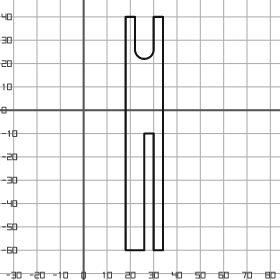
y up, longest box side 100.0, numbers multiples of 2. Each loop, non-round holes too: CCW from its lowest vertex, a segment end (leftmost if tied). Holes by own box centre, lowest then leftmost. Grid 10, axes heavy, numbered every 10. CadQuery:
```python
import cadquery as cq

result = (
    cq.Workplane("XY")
    .moveTo(18.0, -60.0)
    .lineTo(26.0, -60.0)
    .lineTo(26.0, -10.0)
    .lineTo(30.0, -10.0)
    .lineTo(30.0, -60.0)
    .lineTo(34.0, -60.0)
    .lineTo(34.0, 40.0)
    .lineTo(30.0, 40.0)
    .lineTo(30.0, 26.0)
    .threePointArc((26.0, 22.0), (22.0, 26.0))
    .lineTo(22.0, 40.0)
    .lineTo(18.0, 40.0)
    .close()
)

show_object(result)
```